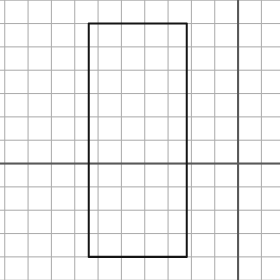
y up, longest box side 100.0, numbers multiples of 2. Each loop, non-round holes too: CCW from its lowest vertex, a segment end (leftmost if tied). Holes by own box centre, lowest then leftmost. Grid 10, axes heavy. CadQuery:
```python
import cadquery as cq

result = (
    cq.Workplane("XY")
    .moveTo(-64.0, -40.0)
    .lineTo(-22.0, -40.0)
    .lineTo(-22.0, 60.0)
    .lineTo(-64.0, 60.0)
    .close()
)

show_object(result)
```